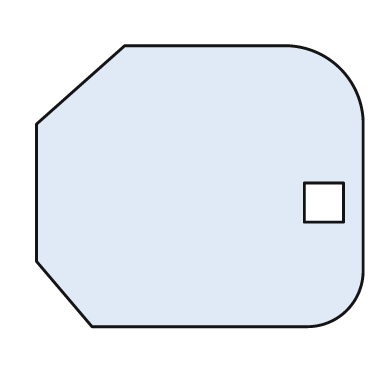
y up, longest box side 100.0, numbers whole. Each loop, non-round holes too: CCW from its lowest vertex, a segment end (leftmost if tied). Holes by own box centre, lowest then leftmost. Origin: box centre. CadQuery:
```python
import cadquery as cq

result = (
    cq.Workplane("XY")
    .moveTo(-33.0, -43.0)
    .lineTo(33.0, -43.0)
    .threePointArc((45.0, -38.0), (50.0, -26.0))
    .lineTo(50.0, 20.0)
    .threePointArc((43.0, 36.0), (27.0, 43.0))
    .lineTo(-23.0, 43.0)
    .lineTo(-50.0, 19.0)
    .lineTo(-50.0, -23.0)
    .close()
    .moveTo(32.0, -11.0)
    .lineTo(44.0, -11.0)
    .lineTo(44.0, 1.0)
    .lineTo(32.0, 1.0)
    .close()
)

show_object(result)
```